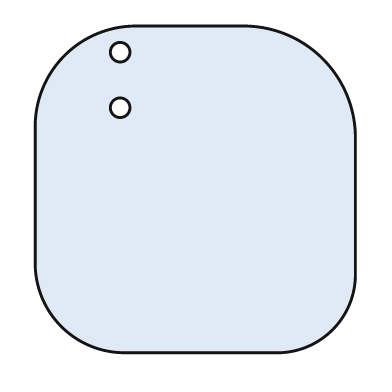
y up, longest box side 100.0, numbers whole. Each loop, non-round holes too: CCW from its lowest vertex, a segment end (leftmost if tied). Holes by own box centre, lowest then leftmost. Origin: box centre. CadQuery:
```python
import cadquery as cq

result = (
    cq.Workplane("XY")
    .moveTo(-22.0, -50.0)
    .lineTo(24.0, -50.0)
    .threePointArc((42.0, -43.0), (49.0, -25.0))
    .lineTo(49.0, 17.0)
    .threePointArc((39.0, 40.0), (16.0, 50.0))
    .lineTo(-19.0, 50.0)
    .threePointArc((-40.0, 41.0), (-49.0, 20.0))
    .lineTo(-49.0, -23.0)
    .threePointArc((-41.0, -42.0), (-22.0, -50.0))
    .close()
    .moveTo(-23.0, 25.0)
    .circle(3.0)
    .moveTo(-23.0, 42.0)
    .circle(3.0)
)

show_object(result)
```